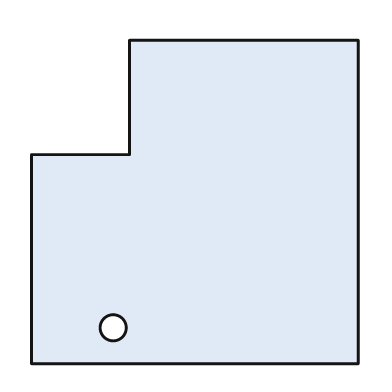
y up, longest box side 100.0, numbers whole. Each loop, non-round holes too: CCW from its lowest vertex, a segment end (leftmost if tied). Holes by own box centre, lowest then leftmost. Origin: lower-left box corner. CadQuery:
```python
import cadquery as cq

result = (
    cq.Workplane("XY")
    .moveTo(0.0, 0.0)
    .lineTo(100.0, 0.0)
    .lineTo(100.0, 99.0)
    .lineTo(30.0, 99.0)
    .lineTo(30.0, 64.0)
    .lineTo(0.0, 64.0)
    .close()
    .moveTo(25.0, 11.0)
    .circle(4.0)
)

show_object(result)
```